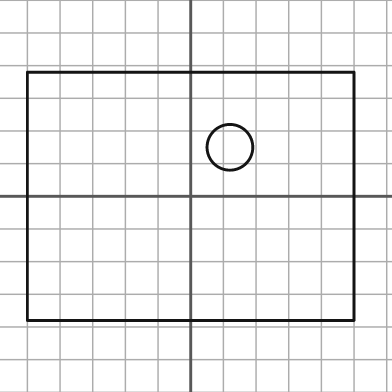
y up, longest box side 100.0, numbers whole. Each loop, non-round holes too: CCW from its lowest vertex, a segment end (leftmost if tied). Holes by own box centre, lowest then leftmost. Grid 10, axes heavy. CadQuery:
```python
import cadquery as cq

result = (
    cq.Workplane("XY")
    .moveTo(-50.0, -38.0)
    .lineTo(50.0, -38.0)
    .lineTo(50.0, 38.0)
    .lineTo(-50.0, 38.0)
    .close()
    .moveTo(12.0, 15.0)
    .circle(7.0)
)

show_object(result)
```